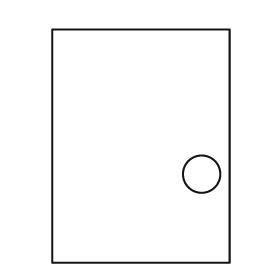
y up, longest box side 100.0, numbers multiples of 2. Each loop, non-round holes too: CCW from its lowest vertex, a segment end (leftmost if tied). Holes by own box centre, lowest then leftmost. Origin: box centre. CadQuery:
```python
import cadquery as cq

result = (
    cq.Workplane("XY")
    .moveTo(-38.0, -50.0)
    .lineTo(38.0, -50.0)
    .lineTo(38.0, 50.0)
    .lineTo(-38.0, 50.0)
    .close()
    .moveTo(26.0, -12.0)
    .circle(8.0)
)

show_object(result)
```